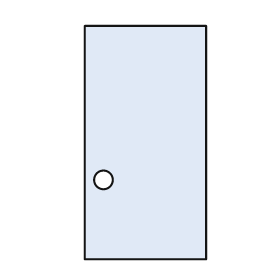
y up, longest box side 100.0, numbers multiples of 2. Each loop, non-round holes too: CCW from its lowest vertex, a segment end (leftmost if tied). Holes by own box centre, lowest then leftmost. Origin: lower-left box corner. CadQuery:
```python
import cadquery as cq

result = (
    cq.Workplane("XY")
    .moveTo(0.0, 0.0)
    .lineTo(52.0, 0.0)
    .lineTo(52.0, 100.0)
    .lineTo(0.0, 100.0)
    .close()
    .moveTo(8.0, 34.0)
    .circle(4.0)
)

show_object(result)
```